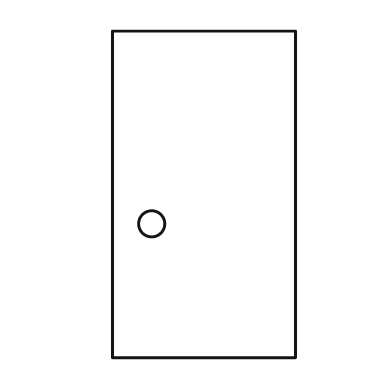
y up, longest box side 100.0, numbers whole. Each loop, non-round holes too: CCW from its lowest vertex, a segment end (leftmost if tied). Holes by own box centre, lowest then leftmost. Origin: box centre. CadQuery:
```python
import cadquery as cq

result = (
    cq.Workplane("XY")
    .moveTo(-28.0, -50.0)
    .lineTo(28.0, -50.0)
    .lineTo(28.0, 50.0)
    .lineTo(-28.0, 50.0)
    .close()
    .moveTo(-16.0, -9.0)
    .circle(4.0)
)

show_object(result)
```